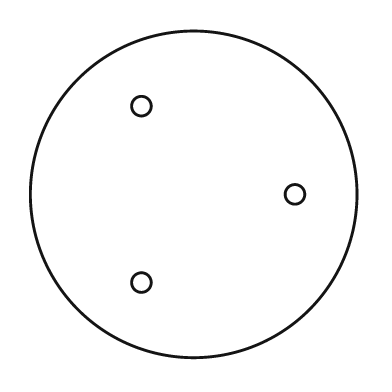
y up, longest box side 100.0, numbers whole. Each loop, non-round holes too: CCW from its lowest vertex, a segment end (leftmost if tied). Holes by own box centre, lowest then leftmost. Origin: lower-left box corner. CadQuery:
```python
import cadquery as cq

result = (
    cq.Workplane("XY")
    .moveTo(50.0, 50.0)
    .circle(50.0)
    .moveTo(34.0, 23.0)
    .circle(3.0)
    .moveTo(81.0, 50.0)
    .circle(3.0)
    .moveTo(34.0, 77.0)
    .circle(3.0)
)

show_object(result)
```